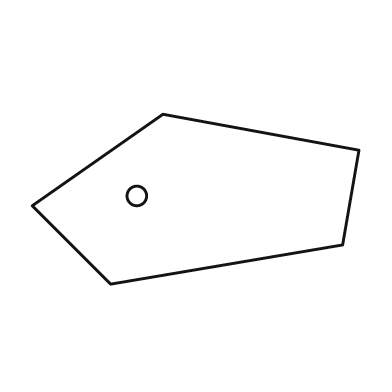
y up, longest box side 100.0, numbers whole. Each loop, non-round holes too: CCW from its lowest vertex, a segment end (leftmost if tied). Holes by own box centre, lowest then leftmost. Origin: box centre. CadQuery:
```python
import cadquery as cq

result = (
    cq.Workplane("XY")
    .moveTo(-26.0, -26.0)
    .lineTo(45.0, -14.0)
    .lineTo(50.0, 15.0)
    .lineTo(-10.0, 26.0)
    .lineTo(-50.0, -2.0)
    .close()
    .moveTo(-18.0, 1.0)
    .circle(3.0)
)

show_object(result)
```